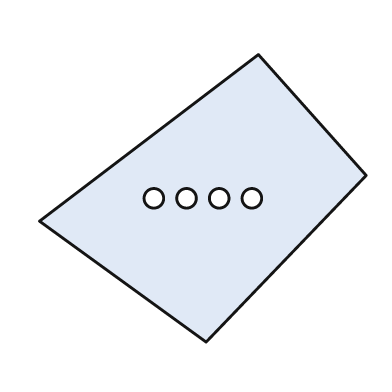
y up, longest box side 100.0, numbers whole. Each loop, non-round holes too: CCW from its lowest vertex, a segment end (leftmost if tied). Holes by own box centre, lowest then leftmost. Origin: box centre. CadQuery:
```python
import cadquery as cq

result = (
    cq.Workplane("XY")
    .moveTo(1.0, -44.0)
    .lineTo(50.0, 7.0)
    .lineTo(17.0, 44.0)
    .lineTo(-50.0, -7.0)
    .close()
    .moveTo(-15.0, 0.0)
    .circle(3.0)
    .moveTo(-5.0, 0.0)
    .circle(3.0)
    .moveTo(5.0, 0.0)
    .circle(3.0)
    .moveTo(15.0, 0.0)
    .circle(3.0)
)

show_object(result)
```